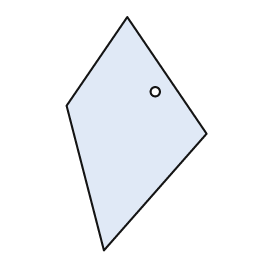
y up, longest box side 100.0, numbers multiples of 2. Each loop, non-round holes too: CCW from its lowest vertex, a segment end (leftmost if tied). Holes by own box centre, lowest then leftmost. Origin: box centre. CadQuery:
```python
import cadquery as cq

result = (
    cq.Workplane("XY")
    .moveTo(-14.0, -50.0)
    .lineTo(30.0, 0.0)
    .lineTo(-4.0, 50.0)
    .lineTo(-30.0, 12.0)
    .close()
    .moveTo(8.0, 18.0)
    .circle(2.0)
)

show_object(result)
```